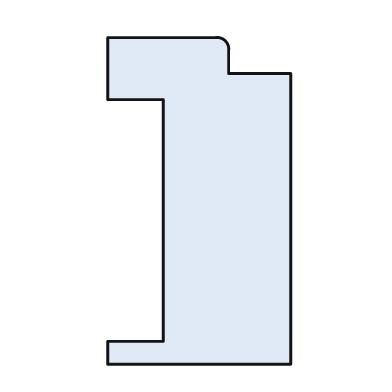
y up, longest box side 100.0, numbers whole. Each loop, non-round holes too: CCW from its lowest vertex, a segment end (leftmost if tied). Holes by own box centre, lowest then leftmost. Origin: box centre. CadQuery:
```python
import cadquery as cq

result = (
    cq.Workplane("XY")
    .moveTo(-28.0, -50.0)
    .lineTo(28.0, -50.0)
    .lineTo(28.0, 39.0)
    .lineTo(9.0, 39.0)
    .lineTo(9.0, 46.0)
    .threePointArc((8.0, 49.0), (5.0, 50.0))
    .lineTo(-28.0, 50.0)
    .lineTo(-28.0, 31.0)
    .lineTo(-11.0, 31.0)
    .lineTo(-11.0, -43.0)
    .lineTo(-28.0, -43.0)
    .close()
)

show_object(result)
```